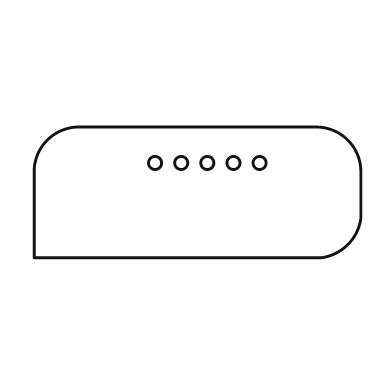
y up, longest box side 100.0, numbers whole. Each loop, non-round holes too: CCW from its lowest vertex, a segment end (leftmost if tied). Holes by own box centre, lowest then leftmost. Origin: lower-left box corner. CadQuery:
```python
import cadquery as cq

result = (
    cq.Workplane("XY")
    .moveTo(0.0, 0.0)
    .lineTo(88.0, 0.0)
    .threePointArc((96.0, 4.0), (100.0, 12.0))
    .lineTo(100.0, 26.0)
    .threePointArc((96.0, 36.0), (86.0, 40.0))
    .lineTo(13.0, 40.0)
    .threePointArc((4.0, 36.0), (0.0, 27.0))
    .close()
    .moveTo(37.0, 29.0)
    .circle(2.0)
    .moveTo(45.0, 29.0)
    .circle(2.0)
    .moveTo(53.0, 29.0)
    .circle(2.0)
    .moveTo(61.0, 29.0)
    .circle(2.0)
    .moveTo(69.0, 29.0)
    .circle(2.0)
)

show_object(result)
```